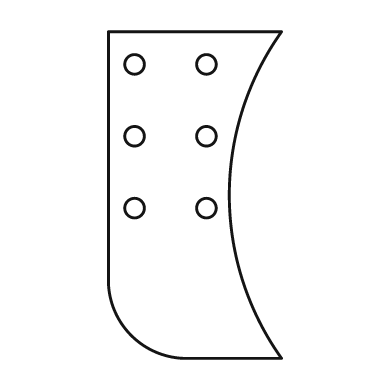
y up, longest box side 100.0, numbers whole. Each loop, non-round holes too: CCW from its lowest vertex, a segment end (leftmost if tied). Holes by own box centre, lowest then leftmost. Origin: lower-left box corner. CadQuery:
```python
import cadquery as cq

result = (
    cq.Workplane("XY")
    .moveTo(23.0, 0.0)
    .lineTo(53.0, 0.0)
    .threePointArc((37.0, 50.0), (53.0, 100.0))
    .lineTo(0.0, 100.0)
    .lineTo(0.0, 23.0)
    .threePointArc((7.0, 7.0), (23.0, 0.0))
    .close()
    .moveTo(8.0, 46.0)
    .circle(3.0)
    .moveTo(30.0, 46.0)
    .circle(3.0)
    .moveTo(8.0, 68.0)
    .circle(3.0)
    .moveTo(30.0, 68.0)
    .circle(3.0)
    .moveTo(8.0, 90.0)
    .circle(3.0)
    .moveTo(30.0, 90.0)
    .circle(3.0)
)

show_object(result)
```